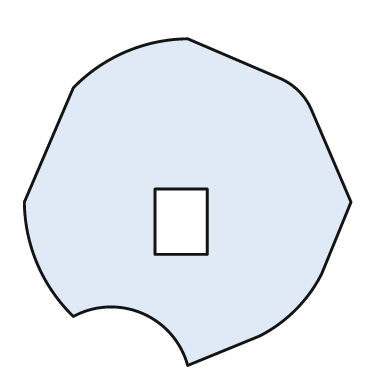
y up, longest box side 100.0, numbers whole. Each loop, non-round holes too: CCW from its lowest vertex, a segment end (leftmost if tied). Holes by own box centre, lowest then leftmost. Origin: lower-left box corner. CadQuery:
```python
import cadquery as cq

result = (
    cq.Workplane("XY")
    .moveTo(50.0, 0.0)
    .lineTo(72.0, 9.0)
    .threePointArc((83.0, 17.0), (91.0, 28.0))
    .lineTo(100.0, 50.0)
    .lineTo(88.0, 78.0)
    .threePointArc((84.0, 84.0), (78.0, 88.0))
    .lineTo(50.0, 100.0)
    .threePointArc((31.0, 96.0), (15.0, 85.0))
    .lineTo(0.0, 50.0)
    .threePointArc((4.0, 31.0), (15.0, 15.0))
    .threePointArc((36.0, 16.0), (50.0, 0.0))
    .close()
    .moveTo(40.0, 34.0)
    .lineTo(56.0, 34.0)
    .lineTo(56.0, 54.0)
    .lineTo(40.0, 54.0)
    .close()
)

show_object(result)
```